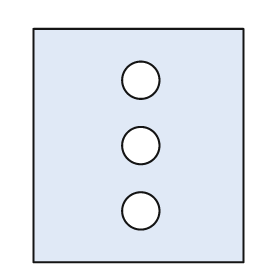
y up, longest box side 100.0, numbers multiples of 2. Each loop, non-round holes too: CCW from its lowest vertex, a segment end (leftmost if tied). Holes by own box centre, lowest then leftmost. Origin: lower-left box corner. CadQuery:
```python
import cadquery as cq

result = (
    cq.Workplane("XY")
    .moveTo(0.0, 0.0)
    .lineTo(90.0, 0.0)
    .lineTo(90.0, 100.0)
    .lineTo(0.0, 100.0)
    .close()
    .moveTo(46.0, 22.0)
    .circle(8.0)
    .moveTo(46.0, 50.0)
    .circle(8.0)
    .moveTo(46.0, 78.0)
    .circle(8.0)
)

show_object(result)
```